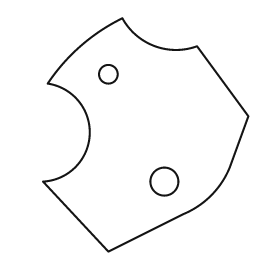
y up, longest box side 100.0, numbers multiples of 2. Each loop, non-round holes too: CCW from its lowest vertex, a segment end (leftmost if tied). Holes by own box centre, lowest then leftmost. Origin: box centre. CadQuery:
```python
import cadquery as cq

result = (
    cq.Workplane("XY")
    .moveTo(-16.0, -50.0)
    .lineTo(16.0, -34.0)
    .threePointArc((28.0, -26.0), (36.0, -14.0))
    .lineTo(44.0, 8.0)
    .lineTo(22.0, 38.0)
    .threePointArc((4.0, 38.0), (-10.0, 50.0))
    .threePointArc((-28.0, 38.0), (-42.0, 22.0))
    .threePointArc((-24.0, 0.0), (-44.0, -20.0))
    .close()
    .moveTo(8.0, -20.0)
    .circle(6.0)
    .moveTo(-16.0, 26.0)
    .circle(4.0)
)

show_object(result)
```